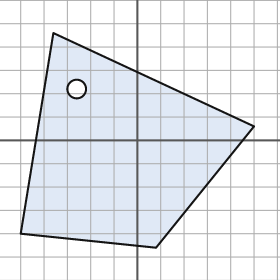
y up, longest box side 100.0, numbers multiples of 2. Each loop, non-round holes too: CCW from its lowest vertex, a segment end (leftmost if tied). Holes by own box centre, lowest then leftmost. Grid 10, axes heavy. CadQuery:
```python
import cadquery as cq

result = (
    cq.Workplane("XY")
    .moveTo(8.0, -46.0)
    .lineTo(50.0, 6.0)
    .lineTo(-36.0, 46.0)
    .lineTo(-50.0, -40.0)
    .close()
    .moveTo(-26.0, 22.0)
    .circle(4.0)
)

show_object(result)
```